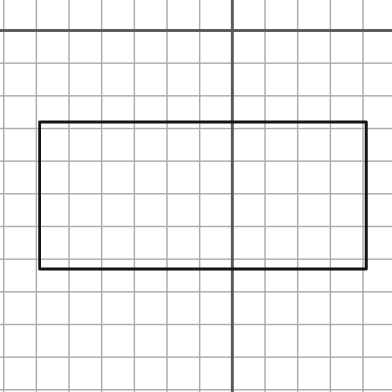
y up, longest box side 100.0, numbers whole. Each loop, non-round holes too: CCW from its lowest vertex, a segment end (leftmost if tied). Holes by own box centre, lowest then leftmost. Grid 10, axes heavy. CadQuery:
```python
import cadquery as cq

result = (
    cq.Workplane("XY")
    .moveTo(-59.0, -73.0)
    .lineTo(41.0, -73.0)
    .lineTo(41.0, -28.0)
    .lineTo(-59.0, -28.0)
    .close()
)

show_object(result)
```